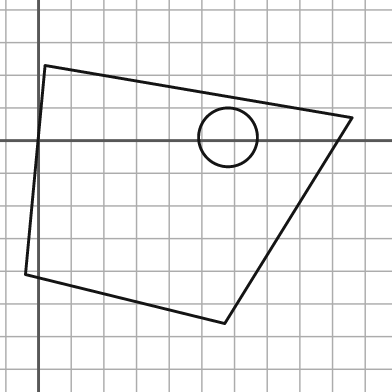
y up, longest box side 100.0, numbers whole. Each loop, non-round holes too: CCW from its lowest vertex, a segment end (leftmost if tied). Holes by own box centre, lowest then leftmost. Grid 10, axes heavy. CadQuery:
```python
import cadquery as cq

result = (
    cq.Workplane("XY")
    .moveTo(57.0, -56.0)
    .lineTo(96.0, 7.0)
    .lineTo(2.0, 23.0)
    .lineTo(-4.0, -41.0)
    .close()
    .moveTo(58.0, 1.0)
    .circle(9.0)
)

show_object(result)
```